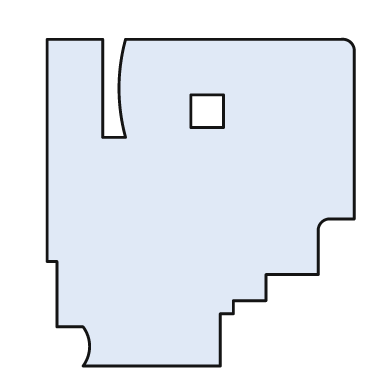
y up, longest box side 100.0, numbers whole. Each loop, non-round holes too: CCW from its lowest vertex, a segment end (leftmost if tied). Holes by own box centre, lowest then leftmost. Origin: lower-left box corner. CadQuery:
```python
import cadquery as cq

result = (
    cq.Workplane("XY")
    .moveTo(11.0, 0.0)
    .lineTo(53.0, 0.0)
    .lineTo(53.0, 16.0)
    .lineTo(57.0, 16.0)
    .lineTo(57.0, 20.0)
    .lineTo(67.0, 20.0)
    .lineTo(67.0, 28.0)
    .lineTo(83.0, 28.0)
    .lineTo(83.0, 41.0)
    .threePointArc((84.0, 44.0), (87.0, 45.0))
    .lineTo(94.0, 45.0)
    .lineTo(94.0, 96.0)
    .threePointArc((93.0, 99.0), (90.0, 100.0))
    .lineTo(24.0, 100.0)
    .threePointArc((22.0, 85.0), (24.0, 70.0))
    .lineTo(17.0, 70.0)
    .lineTo(17.0, 100.0)
    .lineTo(0.0, 100.0)
    .lineTo(0.0, 32.0)
    .lineTo(3.0, 32.0)
    .lineTo(3.0, 12.0)
    .lineTo(11.0, 12.0)
    .threePointArc((13.0, 6.0), (11.0, 0.0))
    .close()
    .moveTo(44.0, 73.0)
    .lineTo(54.0, 73.0)
    .lineTo(54.0, 83.0)
    .lineTo(44.0, 83.0)
    .close()
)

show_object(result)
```